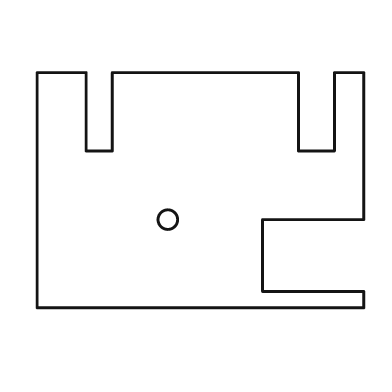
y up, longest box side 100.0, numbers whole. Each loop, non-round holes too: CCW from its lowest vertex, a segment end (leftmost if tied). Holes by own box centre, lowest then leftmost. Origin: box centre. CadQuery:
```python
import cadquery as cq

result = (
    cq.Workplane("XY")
    .moveTo(-50.0, -36.0)
    .lineTo(50.0, -36.0)
    .lineTo(50.0, -31.0)
    .lineTo(19.0, -31.0)
    .lineTo(19.0, -9.0)
    .lineTo(50.0, -9.0)
    .lineTo(50.0, 36.0)
    .lineTo(41.0, 36.0)
    .lineTo(41.0, 12.0)
    .lineTo(30.0, 12.0)
    .lineTo(30.0, 36.0)
    .lineTo(-27.0, 36.0)
    .lineTo(-27.0, 12.0)
    .lineTo(-35.0, 12.0)
    .lineTo(-35.0, 36.0)
    .lineTo(-50.0, 36.0)
    .close()
    .moveTo(-10.0, -9.0)
    .circle(3.0)
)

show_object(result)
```